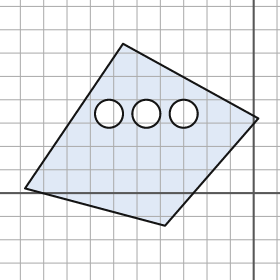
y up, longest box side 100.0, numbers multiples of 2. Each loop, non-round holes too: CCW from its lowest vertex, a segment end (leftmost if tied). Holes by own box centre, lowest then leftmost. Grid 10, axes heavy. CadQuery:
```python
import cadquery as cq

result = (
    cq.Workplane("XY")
    .moveTo(-38.0, -14.0)
    .lineTo(2.0, 32.0)
    .lineTo(-56.0, 64.0)
    .lineTo(-98.0, 2.0)
    .close()
    .moveTo(-62.0, 34.0)
    .circle(6.0)
    .moveTo(-46.0, 34.0)
    .circle(6.0)
    .moveTo(-30.0, 34.0)
    .circle(6.0)
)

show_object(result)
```